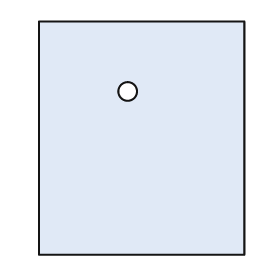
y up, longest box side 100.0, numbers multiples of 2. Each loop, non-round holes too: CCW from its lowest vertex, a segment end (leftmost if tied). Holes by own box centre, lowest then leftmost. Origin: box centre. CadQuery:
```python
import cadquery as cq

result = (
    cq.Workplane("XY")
    .moveTo(-44.0, -50.0)
    .lineTo(44.0, -50.0)
    .lineTo(44.0, 50.0)
    .lineTo(-44.0, 50.0)
    .close()
    .moveTo(-6.0, 20.0)
    .circle(4.0)
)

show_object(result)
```